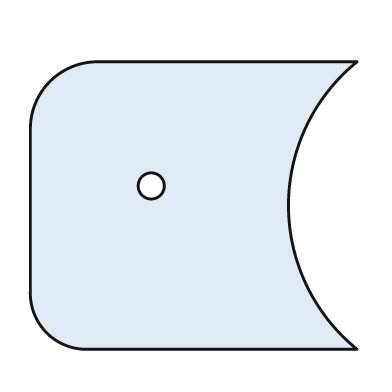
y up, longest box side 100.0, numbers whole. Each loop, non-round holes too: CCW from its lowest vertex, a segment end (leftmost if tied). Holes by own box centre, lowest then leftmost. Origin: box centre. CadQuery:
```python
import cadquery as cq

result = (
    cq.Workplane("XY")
    .moveTo(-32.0, -44.0)
    .lineTo(50.0, -44.0)
    .threePointArc((29.0, 0.0), (50.0, 44.0))
    .lineTo(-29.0, 44.0)
    .threePointArc((-44.0, 38.0), (-50.0, 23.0))
    .lineTo(-50.0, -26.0)
    .threePointArc((-45.0, -39.0), (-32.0, -44.0))
    .close()
    .moveTo(-13.0, 6.0)
    .circle(4.0)
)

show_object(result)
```